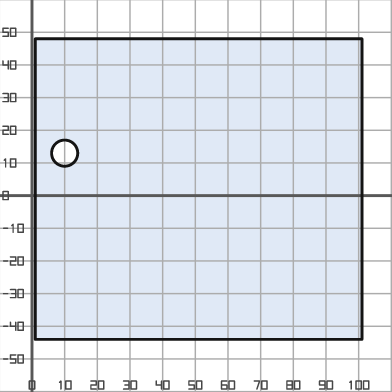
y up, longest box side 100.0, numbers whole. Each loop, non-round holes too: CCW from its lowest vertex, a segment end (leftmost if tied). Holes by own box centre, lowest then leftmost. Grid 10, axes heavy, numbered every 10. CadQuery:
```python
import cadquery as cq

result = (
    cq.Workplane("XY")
    .moveTo(1.0, -44.0)
    .lineTo(101.0, -44.0)
    .lineTo(101.0, 48.0)
    .lineTo(1.0, 48.0)
    .close()
    .moveTo(10.0, 13.0)
    .circle(4.0)
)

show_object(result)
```